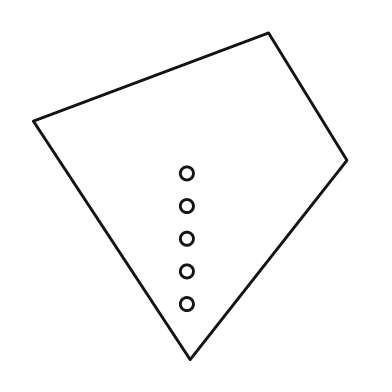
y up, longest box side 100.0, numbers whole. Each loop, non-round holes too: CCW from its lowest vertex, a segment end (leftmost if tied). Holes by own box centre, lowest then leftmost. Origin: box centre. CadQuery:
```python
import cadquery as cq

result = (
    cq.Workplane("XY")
    .moveTo(0.0, -50.0)
    .lineTo(48.0, 11.0)
    .lineTo(24.0, 50.0)
    .lineTo(-48.0, 23.0)
    .close()
    .moveTo(-1.0, -33.0)
    .circle(2.0)
    .moveTo(-1.0, -23.0)
    .circle(2.0)
    .moveTo(-1.0, -13.0)
    .circle(2.0)
    .moveTo(-1.0, -3.0)
    .circle(2.0)
    .moveTo(-1.0, 7.0)
    .circle(2.0)
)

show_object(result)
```